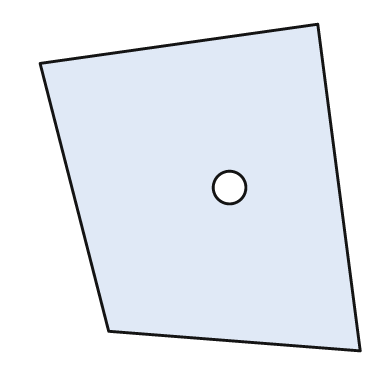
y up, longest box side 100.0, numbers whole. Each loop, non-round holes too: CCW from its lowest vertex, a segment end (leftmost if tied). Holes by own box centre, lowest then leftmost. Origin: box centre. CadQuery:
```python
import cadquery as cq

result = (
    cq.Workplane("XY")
    .moveTo(49.0, -50.0)
    .lineTo(36.0, 50.0)
    .lineTo(-49.0, 38.0)
    .lineTo(-28.0, -44.0)
    .close()
    .moveTo(9.0, 0.0)
    .circle(5.0)
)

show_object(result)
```